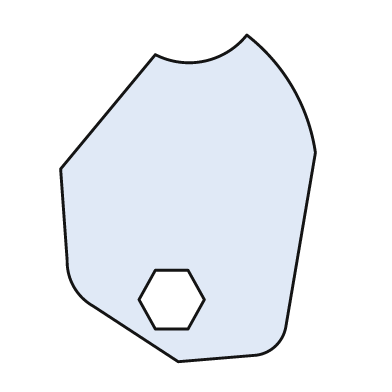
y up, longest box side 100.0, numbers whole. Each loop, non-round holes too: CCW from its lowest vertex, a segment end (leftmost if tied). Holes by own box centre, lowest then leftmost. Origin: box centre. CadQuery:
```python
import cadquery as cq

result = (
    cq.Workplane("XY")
    .moveTo(-3.0, -50.0)
    .lineTo(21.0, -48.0)
    .threePointArc((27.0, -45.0), (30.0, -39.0))
    .lineTo(39.0, 14.0)
    .threePointArc((32.0, 34.0), (18.0, 50.0))
    .threePointArc((5.0, 42.0), (-10.0, 44.0))
    .lineTo(-39.0, 9.0)
    .lineTo(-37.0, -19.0)
    .threePointArc((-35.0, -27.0), (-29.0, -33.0))
    .close()
    .moveTo(-10.0, -40.0)
    .lineTo(0.0, -40.0)
    .lineTo(5.0, -31.0)
    .lineTo(0.0, -22.0)
    .lineTo(-10.0, -22.0)
    .lineTo(-15.0, -31.0)
    .close()
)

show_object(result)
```